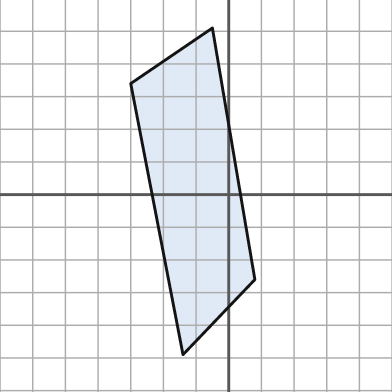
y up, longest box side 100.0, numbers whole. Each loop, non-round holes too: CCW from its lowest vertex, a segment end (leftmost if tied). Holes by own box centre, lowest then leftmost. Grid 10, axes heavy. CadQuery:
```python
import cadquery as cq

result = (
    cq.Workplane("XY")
    .moveTo(-14.0, -49.0)
    .lineTo(8.0, -26.0)
    .lineTo(-5.0, 51.0)
    .lineTo(-30.0, 34.0)
    .close()
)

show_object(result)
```